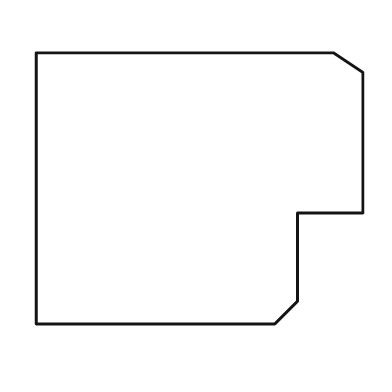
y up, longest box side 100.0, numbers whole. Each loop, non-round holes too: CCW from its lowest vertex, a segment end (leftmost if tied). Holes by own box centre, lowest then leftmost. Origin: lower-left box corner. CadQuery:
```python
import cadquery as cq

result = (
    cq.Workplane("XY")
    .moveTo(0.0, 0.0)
    .lineTo(73.0, 0.0)
    .lineTo(80.0, 7.0)
    .lineTo(80.0, 34.0)
    .lineTo(100.0, 34.0)
    .lineTo(100.0, 77.0)
    .lineTo(91.0, 83.0)
    .lineTo(0.0, 83.0)
    .close()
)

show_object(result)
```